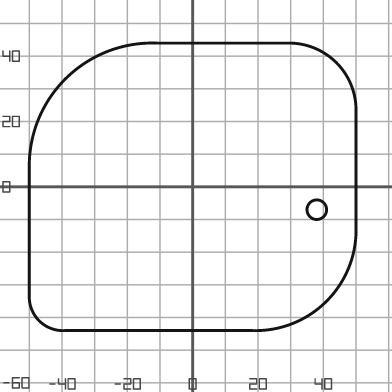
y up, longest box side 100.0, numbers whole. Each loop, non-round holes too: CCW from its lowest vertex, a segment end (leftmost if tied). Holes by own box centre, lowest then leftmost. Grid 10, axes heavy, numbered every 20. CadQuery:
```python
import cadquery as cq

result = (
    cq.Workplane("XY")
    .moveTo(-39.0, -44.0)
    .lineTo(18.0, -44.0)
    .threePointArc((41.0, -35.0), (50.0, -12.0))
    .lineTo(50.0, 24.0)
    .threePointArc((44.0, 38.0), (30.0, 44.0))
    .lineTo(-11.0, 44.0)
    .threePointArc((-39.0, 33.0), (-50.0, 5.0))
    .lineTo(-50.0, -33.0)
    .threePointArc((-47.0, -41.0), (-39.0, -44.0))
    .close()
    .moveTo(38.0, -7.0)
    .circle(3.0)
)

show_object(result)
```